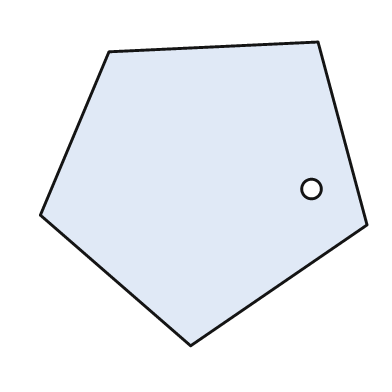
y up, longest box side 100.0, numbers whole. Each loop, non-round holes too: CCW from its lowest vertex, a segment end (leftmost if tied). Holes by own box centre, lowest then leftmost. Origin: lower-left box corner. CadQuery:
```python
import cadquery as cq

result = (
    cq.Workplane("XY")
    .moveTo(46.0, 0.0)
    .lineTo(100.0, 37.0)
    .lineTo(85.0, 93.0)
    .lineTo(21.0, 90.0)
    .lineTo(0.0, 40.0)
    .close()
    .moveTo(83.0, 48.0)
    .circle(3.0)
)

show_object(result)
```